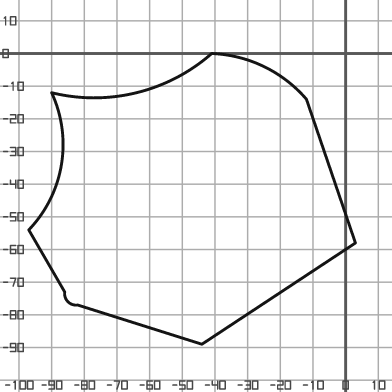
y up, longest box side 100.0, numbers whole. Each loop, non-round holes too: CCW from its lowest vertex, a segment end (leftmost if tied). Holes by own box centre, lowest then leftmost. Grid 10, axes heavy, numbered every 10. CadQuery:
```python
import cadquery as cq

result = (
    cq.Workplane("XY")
    .moveTo(-44.0, -89.0)
    .lineTo(3.0, -58.0)
    .lineTo(-12.0, -14.0)
    .threePointArc((-25.0, -4.0), (-41.0, 0.0))
    .threePointArc((-64.0, -12.0), (-90.0, -12.0))
    .threePointArc((-87.0, -34.0), (-97.0, -54.0))
    .lineTo(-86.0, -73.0)
    .threePointArc((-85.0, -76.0), (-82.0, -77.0))
    .close()
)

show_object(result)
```